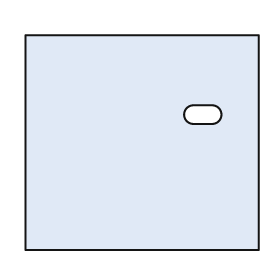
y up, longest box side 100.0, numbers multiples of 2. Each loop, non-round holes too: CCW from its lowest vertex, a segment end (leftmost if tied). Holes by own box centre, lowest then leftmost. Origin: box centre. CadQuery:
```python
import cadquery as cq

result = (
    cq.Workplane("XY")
    .moveTo(-50.0, -46.0)
    .lineTo(50.0, -46.0)
    .lineTo(50.0, 46.0)
    .lineTo(-50.0, 46.0)
    .close()
    .moveTo(22.0, 8.0)
    .lineTo(30.0, 8.0)
    .threePointArc((34.0, 12.0), (30.0, 16.0))
    .lineTo(22.0, 16.0)
    .threePointArc((18.0, 12.0), (22.0, 8.0))
    .close()
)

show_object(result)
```